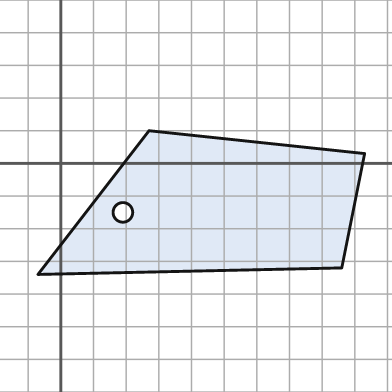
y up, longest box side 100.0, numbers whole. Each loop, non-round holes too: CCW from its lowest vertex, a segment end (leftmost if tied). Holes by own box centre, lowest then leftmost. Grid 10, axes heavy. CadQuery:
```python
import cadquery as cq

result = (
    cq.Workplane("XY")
    .moveTo(-7.0, -34.0)
    .lineTo(86.0, -32.0)
    .lineTo(93.0, 3.0)
    .lineTo(27.0, 10.0)
    .close()
    .moveTo(19.0, -15.0)
    .circle(3.0)
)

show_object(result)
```